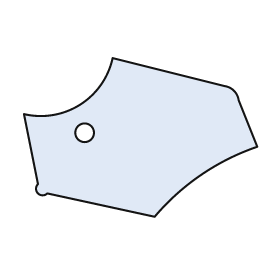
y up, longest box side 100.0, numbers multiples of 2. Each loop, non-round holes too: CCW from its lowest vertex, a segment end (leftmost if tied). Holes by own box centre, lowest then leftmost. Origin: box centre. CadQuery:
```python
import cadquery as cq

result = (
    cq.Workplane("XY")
    .moveTo(6.0, -34.0)
    .threePointArc((26.0, -16.0), (50.0, -4.0))
    .lineTo(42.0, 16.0)
    .threePointArc((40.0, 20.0), (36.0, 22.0))
    .lineTo(-12.0, 34.0)
    .threePointArc((-26.0, 14.0), (-50.0, 10.0))
    .lineTo(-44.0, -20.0)
    .threePointArc((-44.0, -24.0), (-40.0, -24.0))
    .close()
    .moveTo(-24.0, 2.0)
    .circle(4.0)
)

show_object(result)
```